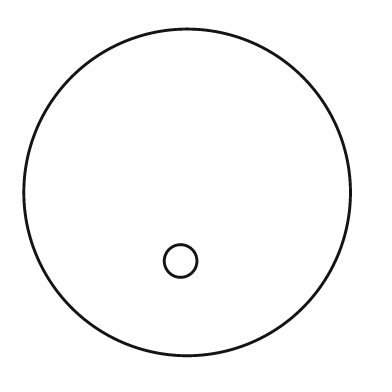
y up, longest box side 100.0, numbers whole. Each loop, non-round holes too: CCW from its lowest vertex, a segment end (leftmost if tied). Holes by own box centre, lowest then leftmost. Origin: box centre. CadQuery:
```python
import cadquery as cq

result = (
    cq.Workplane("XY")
    .moveTo(0.0, 0.0)
    .circle(50.0)
    .moveTo(-2.0, -21.0)
    .circle(5.0)
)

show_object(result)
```